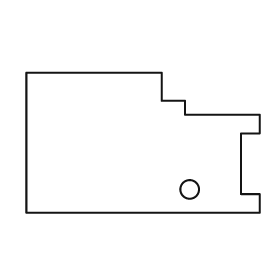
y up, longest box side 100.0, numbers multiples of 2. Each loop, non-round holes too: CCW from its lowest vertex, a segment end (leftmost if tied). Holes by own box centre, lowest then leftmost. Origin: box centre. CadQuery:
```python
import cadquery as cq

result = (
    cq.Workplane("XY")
    .moveTo(-50.0, -30.0)
    .lineTo(50.0, -30.0)
    .lineTo(50.0, -22.0)
    .lineTo(42.0, -22.0)
    .lineTo(42.0, 4.0)
    .lineTo(50.0, 4.0)
    .lineTo(50.0, 12.0)
    .lineTo(18.0, 12.0)
    .lineTo(18.0, 18.0)
    .lineTo(8.0, 18.0)
    .lineTo(8.0, 30.0)
    .lineTo(-50.0, 30.0)
    .close()
    .moveTo(20.0, -20.0)
    .circle(4.0)
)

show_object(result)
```